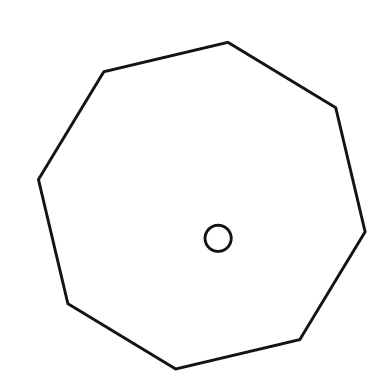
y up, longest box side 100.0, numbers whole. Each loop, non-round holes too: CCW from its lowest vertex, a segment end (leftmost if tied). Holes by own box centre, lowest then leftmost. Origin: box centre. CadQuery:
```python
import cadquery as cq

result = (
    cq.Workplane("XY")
    .moveTo(-8.0, -50.0)
    .lineTo(30.0, -41.0)
    .lineTo(50.0, -8.0)
    .lineTo(41.0, 30.0)
    .lineTo(8.0, 50.0)
    .lineTo(-30.0, 41.0)
    .lineTo(-50.0, 8.0)
    .lineTo(-41.0, -30.0)
    .close()
    .moveTo(5.0, -10.0)
    .circle(4.0)
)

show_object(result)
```